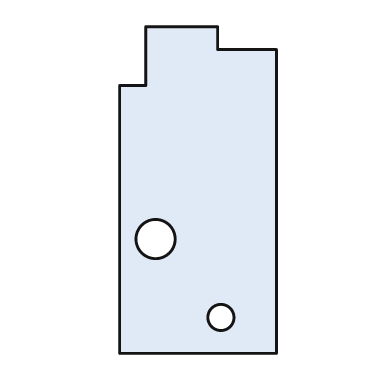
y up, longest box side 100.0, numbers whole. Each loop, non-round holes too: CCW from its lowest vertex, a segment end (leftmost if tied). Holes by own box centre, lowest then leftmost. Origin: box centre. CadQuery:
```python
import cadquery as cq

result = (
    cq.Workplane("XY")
    .moveTo(-24.0, -50.0)
    .lineTo(24.0, -50.0)
    .lineTo(24.0, 43.0)
    .lineTo(6.0, 43.0)
    .lineTo(6.0, 50.0)
    .lineTo(-16.0, 50.0)
    .lineTo(-16.0, 32.0)
    .lineTo(-24.0, 32.0)
    .close()
    .moveTo(7.0, -39.0)
    .circle(4.0)
    .moveTo(-13.0, -15.0)
    .circle(6.0)
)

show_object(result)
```